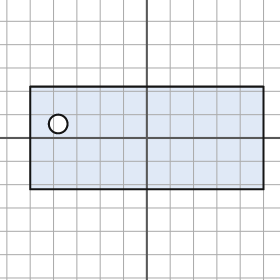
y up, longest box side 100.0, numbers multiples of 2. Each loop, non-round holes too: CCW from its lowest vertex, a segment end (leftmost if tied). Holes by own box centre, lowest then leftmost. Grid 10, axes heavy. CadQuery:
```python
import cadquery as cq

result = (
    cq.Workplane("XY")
    .moveTo(-50.0, -22.0)
    .lineTo(50.0, -22.0)
    .lineTo(50.0, 22.0)
    .lineTo(-50.0, 22.0)
    .close()
    .moveTo(-38.0, 6.0)
    .circle(4.0)
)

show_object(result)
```